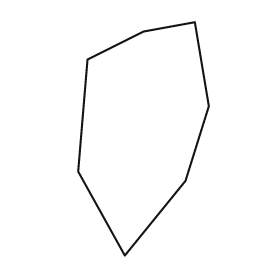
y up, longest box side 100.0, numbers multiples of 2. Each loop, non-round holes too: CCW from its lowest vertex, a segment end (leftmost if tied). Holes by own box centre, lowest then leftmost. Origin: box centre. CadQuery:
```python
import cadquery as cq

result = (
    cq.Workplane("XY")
    .moveTo(-8.0, -50.0)
    .lineTo(18.0, -18.0)
    .lineTo(28.0, 14.0)
    .lineTo(22.0, 50.0)
    .lineTo(0.0, 46.0)
    .lineTo(-24.0, 34.0)
    .lineTo(-28.0, -14.0)
    .close()
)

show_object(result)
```